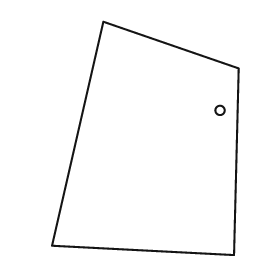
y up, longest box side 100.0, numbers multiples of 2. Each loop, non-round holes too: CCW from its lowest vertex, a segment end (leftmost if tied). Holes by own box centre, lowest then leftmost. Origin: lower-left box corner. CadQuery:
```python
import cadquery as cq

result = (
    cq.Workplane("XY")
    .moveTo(78.0, 0.0)
    .lineTo(80.0, 80.0)
    .lineTo(22.0, 100.0)
    .lineTo(0.0, 4.0)
    .close()
    .moveTo(72.0, 62.0)
    .circle(2.0)
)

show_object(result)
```